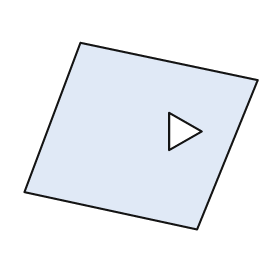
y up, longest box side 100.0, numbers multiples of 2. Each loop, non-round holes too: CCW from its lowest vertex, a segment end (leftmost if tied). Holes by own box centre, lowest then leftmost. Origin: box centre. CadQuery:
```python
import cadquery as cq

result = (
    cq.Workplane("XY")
    .moveTo(24.0, -40.0)
    .lineTo(50.0, 24.0)
    .lineTo(-26.0, 40.0)
    .lineTo(-50.0, -24.0)
    .close()
    .moveTo(12.0, -6.0)
    .lineTo(26.0, 2.0)
    .lineTo(12.0, 10.0)
    .close()
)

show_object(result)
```